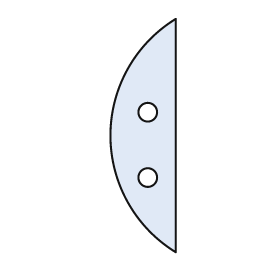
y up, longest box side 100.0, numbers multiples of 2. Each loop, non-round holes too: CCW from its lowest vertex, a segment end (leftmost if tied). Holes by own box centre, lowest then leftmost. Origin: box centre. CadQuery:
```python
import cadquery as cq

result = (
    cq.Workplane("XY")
    .moveTo(14.0, -50.0)
    .lineTo(14.0, 50.0)
    .threePointArc((-14.0, 0.0), (14.0, -50.0))
    .close()
    .moveTo(2.0, -18.0)
    .circle(4.0)
    .moveTo(2.0, 10.0)
    .circle(4.0)
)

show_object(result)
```